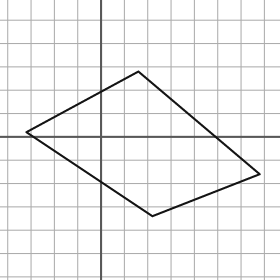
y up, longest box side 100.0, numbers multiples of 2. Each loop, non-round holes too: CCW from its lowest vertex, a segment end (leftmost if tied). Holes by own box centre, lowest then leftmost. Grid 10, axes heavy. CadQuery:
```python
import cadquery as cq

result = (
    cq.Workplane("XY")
    .moveTo(22.0, -34.0)
    .lineTo(68.0, -16.0)
    .lineTo(16.0, 28.0)
    .lineTo(-32.0, 2.0)
    .close()
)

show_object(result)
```